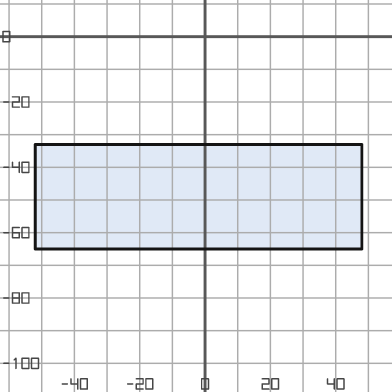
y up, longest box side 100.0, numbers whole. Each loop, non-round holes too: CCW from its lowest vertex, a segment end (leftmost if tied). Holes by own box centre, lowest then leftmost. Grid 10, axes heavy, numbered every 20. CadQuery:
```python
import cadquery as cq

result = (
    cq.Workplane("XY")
    .moveTo(-52.0, -65.0)
    .lineTo(48.0, -65.0)
    .lineTo(48.0, -33.0)
    .lineTo(-52.0, -33.0)
    .close()
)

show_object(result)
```